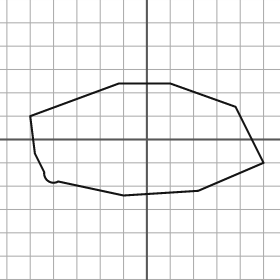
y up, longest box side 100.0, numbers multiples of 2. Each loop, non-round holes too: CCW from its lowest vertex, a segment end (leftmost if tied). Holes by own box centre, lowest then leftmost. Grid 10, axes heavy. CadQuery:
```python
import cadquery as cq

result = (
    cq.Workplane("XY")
    .moveTo(-10.0, -24.0)
    .lineTo(22.0, -22.0)
    .lineTo(50.0, -10.0)
    .lineTo(38.0, 14.0)
    .lineTo(10.0, 24.0)
    .lineTo(-12.0, 24.0)
    .lineTo(-50.0, 10.0)
    .lineTo(-48.0, -6.0)
    .lineTo(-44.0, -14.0)
    .threePointArc((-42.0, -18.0), (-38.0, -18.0))
    .close()
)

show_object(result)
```